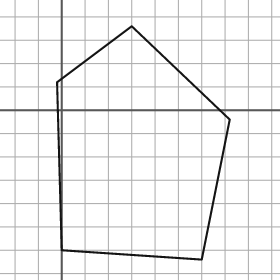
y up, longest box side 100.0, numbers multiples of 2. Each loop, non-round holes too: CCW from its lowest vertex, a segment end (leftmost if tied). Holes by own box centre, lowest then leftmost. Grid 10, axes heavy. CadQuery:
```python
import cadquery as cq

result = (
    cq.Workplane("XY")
    .moveTo(60.0, -64.0)
    .lineTo(72.0, -4.0)
    .lineTo(30.0, 36.0)
    .lineTo(-2.0, 12.0)
    .lineTo(0.0, -60.0)
    .close()
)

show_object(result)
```